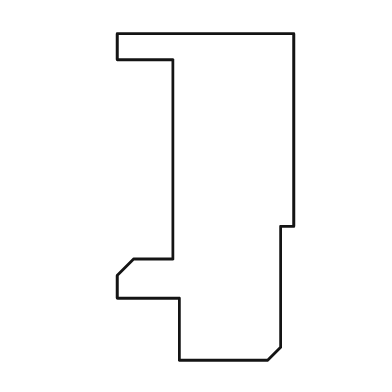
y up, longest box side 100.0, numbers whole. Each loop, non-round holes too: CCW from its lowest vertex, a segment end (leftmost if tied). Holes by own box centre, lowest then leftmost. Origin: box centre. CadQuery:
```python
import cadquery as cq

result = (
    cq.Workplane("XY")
    .moveTo(-8.0, -50.0)
    .lineTo(19.0, -50.0)
    .lineTo(23.0, -46.0)
    .lineTo(23.0, -9.0)
    .lineTo(27.0, -9.0)
    .lineTo(27.0, 50.0)
    .lineTo(-27.0, 50.0)
    .lineTo(-27.0, 42.0)
    .lineTo(-10.0, 42.0)
    .lineTo(-10.0, -19.0)
    .lineTo(-22.0, -19.0)
    .lineTo(-27.0, -24.0)
    .lineTo(-27.0, -31.0)
    .lineTo(-8.0, -31.0)
    .close()
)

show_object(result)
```